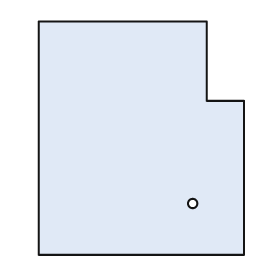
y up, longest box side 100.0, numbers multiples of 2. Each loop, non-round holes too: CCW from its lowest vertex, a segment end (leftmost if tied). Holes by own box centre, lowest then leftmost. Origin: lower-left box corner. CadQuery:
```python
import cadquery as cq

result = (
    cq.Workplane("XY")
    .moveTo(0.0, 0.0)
    .lineTo(88.0, 0.0)
    .lineTo(88.0, 66.0)
    .lineTo(72.0, 66.0)
    .lineTo(72.0, 100.0)
    .lineTo(0.0, 100.0)
    .close()
    .moveTo(66.0, 22.0)
    .circle(2.0)
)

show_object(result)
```